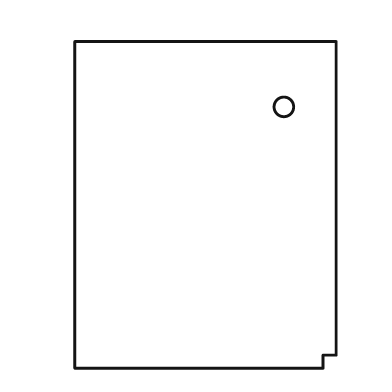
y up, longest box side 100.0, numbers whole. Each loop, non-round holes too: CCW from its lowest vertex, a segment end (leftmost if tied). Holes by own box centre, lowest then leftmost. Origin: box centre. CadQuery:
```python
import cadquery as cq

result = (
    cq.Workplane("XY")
    .moveTo(-40.0, -50.0)
    .lineTo(36.0, -50.0)
    .lineTo(36.0, -46.0)
    .lineTo(40.0, -46.0)
    .lineTo(40.0, 50.0)
    .lineTo(-40.0, 50.0)
    .close()
    .moveTo(24.0, 30.0)
    .circle(3.0)
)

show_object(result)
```